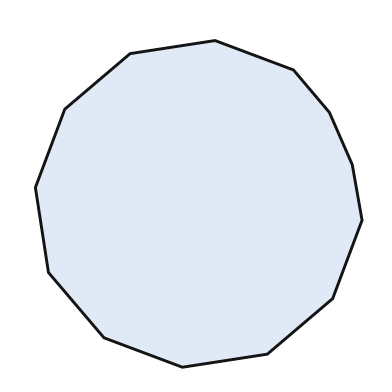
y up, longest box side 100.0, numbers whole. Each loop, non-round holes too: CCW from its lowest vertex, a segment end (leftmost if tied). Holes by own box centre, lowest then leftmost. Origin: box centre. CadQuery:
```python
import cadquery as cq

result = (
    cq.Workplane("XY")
    .moveTo(-5.0, -50.0)
    .lineTo(21.0, -46.0)
    .lineTo(41.0, -29.0)
    .lineTo(50.0, -5.0)
    .lineTo(47.0, 12.0)
    .lineTo(40.0, 28.0)
    .lineTo(29.0, 41.0)
    .lineTo(5.0, 50.0)
    .lineTo(-21.0, 46.0)
    .lineTo(-41.0, 29.0)
    .lineTo(-50.0, 5.0)
    .lineTo(-46.0, -21.0)
    .lineTo(-29.0, -41.0)
    .close()
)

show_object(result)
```